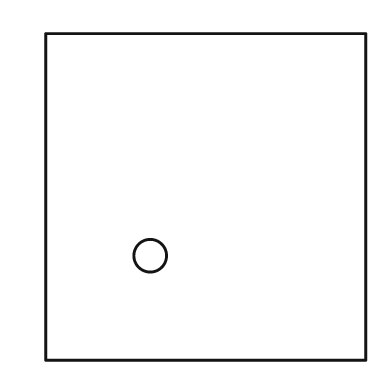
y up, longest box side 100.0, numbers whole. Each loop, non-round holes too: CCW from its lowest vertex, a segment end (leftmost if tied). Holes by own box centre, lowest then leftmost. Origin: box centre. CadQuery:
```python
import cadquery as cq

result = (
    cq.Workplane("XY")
    .moveTo(-49.0, -50.0)
    .lineTo(49.0, -50.0)
    .lineTo(49.0, 50.0)
    .lineTo(-49.0, 50.0)
    .close()
    .moveTo(-17.0, -18.0)
    .circle(5.0)
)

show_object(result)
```